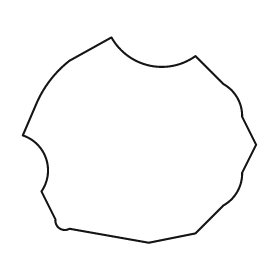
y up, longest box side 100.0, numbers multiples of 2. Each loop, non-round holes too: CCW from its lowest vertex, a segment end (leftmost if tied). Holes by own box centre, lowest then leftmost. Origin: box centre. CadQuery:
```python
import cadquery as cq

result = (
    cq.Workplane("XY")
    .moveTo(4.0, -44.0)
    .lineTo(24.0, -40.0)
    .lineTo(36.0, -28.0)
    .threePointArc((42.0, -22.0), (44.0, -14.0))
    .lineTo(50.0, -2.0)
    .lineTo(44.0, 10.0)
    .threePointArc((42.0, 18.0), (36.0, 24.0))
    .lineTo(24.0, 36.0)
    .threePointArc((4.0, 32.0), (-12.0, 44.0))
    .lineTo(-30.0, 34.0)
    .threePointArc((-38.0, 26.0), (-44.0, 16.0))
    .lineTo(-50.0, 2.0)
    .threePointArc((-40.0, -8.0), (-42.0, -22.0))
    .lineTo(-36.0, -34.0)
    .threePointArc((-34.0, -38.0), (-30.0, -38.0))
    .close()
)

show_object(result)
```